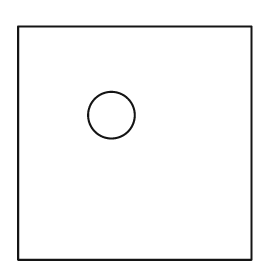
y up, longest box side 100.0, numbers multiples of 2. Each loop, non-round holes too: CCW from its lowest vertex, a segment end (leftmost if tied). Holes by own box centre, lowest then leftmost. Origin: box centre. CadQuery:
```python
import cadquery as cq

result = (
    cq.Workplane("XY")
    .moveTo(-50.0, -50.0)
    .lineTo(50.0, -50.0)
    .lineTo(50.0, 50.0)
    .lineTo(-50.0, 50.0)
    .close()
    .moveTo(-10.0, 12.0)
    .circle(10.0)
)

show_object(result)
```